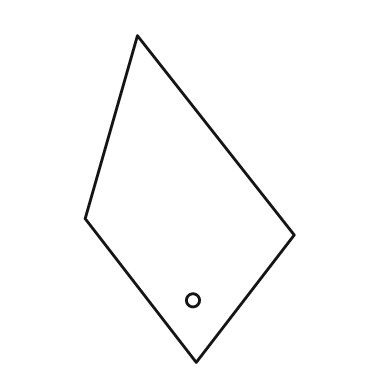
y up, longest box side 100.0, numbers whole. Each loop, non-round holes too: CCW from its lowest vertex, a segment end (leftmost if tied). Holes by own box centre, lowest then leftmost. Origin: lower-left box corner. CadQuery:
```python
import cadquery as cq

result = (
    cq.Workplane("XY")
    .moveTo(34.0, 0.0)
    .lineTo(64.0, 39.0)
    .lineTo(16.0, 100.0)
    .lineTo(0.0, 44.0)
    .close()
    .moveTo(33.0, 19.0)
    .circle(2.0)
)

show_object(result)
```